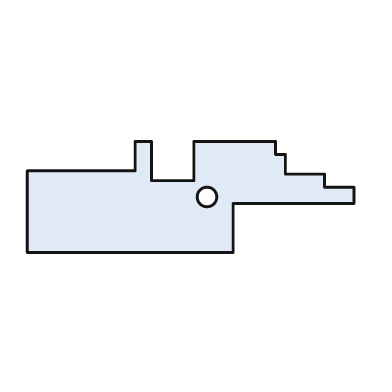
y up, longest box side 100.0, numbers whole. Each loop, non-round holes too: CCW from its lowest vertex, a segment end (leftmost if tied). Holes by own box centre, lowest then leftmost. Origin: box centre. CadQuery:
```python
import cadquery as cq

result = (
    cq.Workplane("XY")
    .moveTo(-50.0, -17.0)
    .lineTo(13.0, -17.0)
    .lineTo(13.0, -2.0)
    .lineTo(50.0, -2.0)
    .lineTo(50.0, 3.0)
    .lineTo(41.0, 3.0)
    .lineTo(41.0, 7.0)
    .lineTo(29.0, 7.0)
    .lineTo(29.0, 13.0)
    .lineTo(26.0, 13.0)
    .lineTo(26.0, 17.0)
    .lineTo(1.0, 17.0)
    .lineTo(1.0, 5.0)
    .lineTo(-12.0, 5.0)
    .lineTo(-12.0, 17.0)
    .lineTo(-17.0, 17.0)
    .lineTo(-17.0, 8.0)
    .lineTo(-50.0, 8.0)
    .close()
    .moveTo(5.0, 0.0)
    .circle(3.0)
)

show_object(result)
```